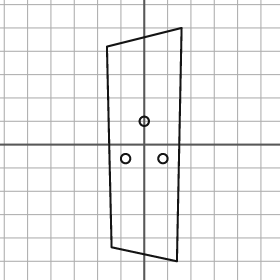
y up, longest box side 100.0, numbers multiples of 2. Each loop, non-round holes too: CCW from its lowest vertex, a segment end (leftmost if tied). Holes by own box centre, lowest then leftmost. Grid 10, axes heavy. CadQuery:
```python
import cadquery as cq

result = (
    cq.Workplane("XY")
    .moveTo(14.0, -50.0)
    .lineTo(16.0, 50.0)
    .lineTo(-16.0, 42.0)
    .lineTo(-14.0, -44.0)
    .close()
    .moveTo(-8.0, -6.0)
    .circle(2.0)
    .moveTo(8.0, -6.0)
    .circle(2.0)
    .moveTo(0.0, 10.0)
    .circle(2.0)
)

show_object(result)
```